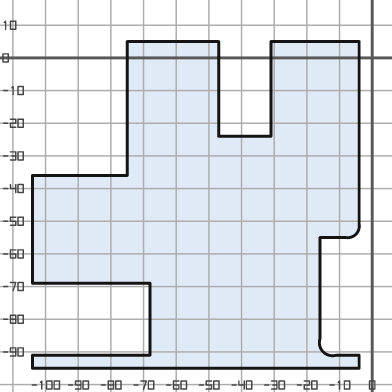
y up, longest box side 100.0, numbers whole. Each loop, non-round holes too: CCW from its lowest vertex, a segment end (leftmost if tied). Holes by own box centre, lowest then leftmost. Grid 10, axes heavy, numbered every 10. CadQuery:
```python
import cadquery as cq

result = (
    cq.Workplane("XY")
    .moveTo(-104.0, -95.0)
    .lineTo(-4.0, -95.0)
    .lineTo(-4.0, -91.0)
    .lineTo(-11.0, -91.0)
    .threePointArc((-15.0, -90.0), (-16.0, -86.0))
    .lineTo(-16.0, -55.0)
    .lineTo(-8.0, -55.0)
    .threePointArc((-5.0, -54.0), (-4.0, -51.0))
    .lineTo(-4.0, 5.0)
    .lineTo(-31.0, 5.0)
    .lineTo(-31.0, -24.0)
    .lineTo(-47.0, -24.0)
    .lineTo(-47.0, 5.0)
    .lineTo(-75.0, 5.0)
    .lineTo(-75.0, -36.0)
    .lineTo(-104.0, -36.0)
    .lineTo(-104.0, -69.0)
    .lineTo(-68.0, -69.0)
    .lineTo(-68.0, -91.0)
    .lineTo(-104.0, -91.0)
    .close()
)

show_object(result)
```